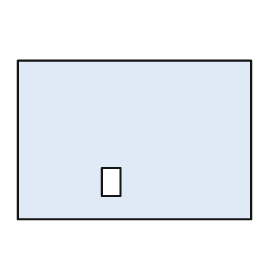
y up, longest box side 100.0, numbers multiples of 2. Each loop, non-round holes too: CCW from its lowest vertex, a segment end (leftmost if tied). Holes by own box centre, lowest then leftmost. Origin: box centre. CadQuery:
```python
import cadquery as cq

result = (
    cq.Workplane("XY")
    .moveTo(-50.0, -34.0)
    .lineTo(50.0, -34.0)
    .lineTo(50.0, 34.0)
    .lineTo(-50.0, 34.0)
    .close()
    .moveTo(-14.0, -24.0)
    .lineTo(-6.0, -24.0)
    .lineTo(-6.0, -12.0)
    .lineTo(-14.0, -12.0)
    .close()
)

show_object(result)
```